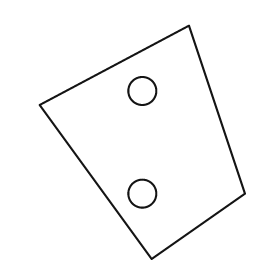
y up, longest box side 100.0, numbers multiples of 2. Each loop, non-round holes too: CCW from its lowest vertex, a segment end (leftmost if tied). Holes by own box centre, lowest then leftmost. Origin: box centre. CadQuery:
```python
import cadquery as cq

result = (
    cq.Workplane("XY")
    .moveTo(4.0, -50.0)
    .lineTo(44.0, -22.0)
    .lineTo(20.0, 50.0)
    .lineTo(-44.0, 16.0)
    .close()
    .moveTo(0.0, -22.0)
    .circle(6.0)
    .moveTo(0.0, 22.0)
    .circle(6.0)
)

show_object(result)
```